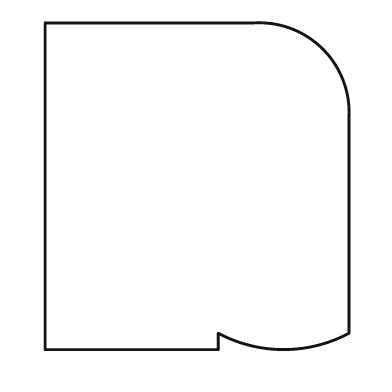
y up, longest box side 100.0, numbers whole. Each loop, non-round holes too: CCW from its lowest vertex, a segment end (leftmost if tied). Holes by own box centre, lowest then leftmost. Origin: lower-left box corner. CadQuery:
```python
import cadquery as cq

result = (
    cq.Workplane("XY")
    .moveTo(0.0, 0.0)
    .lineTo(53.0, 0.0)
    .lineTo(53.0, 5.0)
    .threePointArc((73.0, 0.0), (93.0, 5.0))
    .lineTo(93.0, 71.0)
    .threePointArc((85.0, 92.0), (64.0, 100.0))
    .lineTo(0.0, 100.0)
    .close()
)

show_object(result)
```